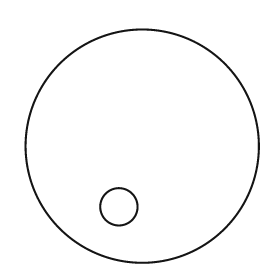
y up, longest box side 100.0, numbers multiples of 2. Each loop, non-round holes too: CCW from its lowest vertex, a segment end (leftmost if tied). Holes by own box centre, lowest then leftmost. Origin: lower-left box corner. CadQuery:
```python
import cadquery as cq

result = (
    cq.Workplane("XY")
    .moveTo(50.0, 50.0)
    .circle(50.0)
    .moveTo(40.0, 24.0)
    .circle(8.0)
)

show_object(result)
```